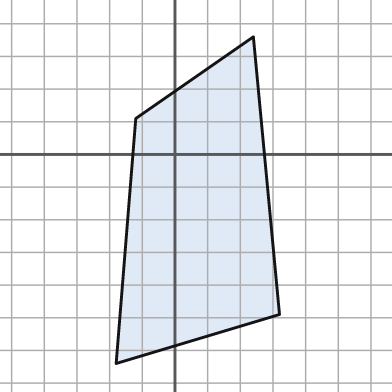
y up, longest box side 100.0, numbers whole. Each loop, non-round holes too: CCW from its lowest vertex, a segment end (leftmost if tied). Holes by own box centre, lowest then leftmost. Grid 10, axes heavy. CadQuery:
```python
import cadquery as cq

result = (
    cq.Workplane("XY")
    .moveTo(-18.0, -64.0)
    .lineTo(32.0, -49.0)
    .lineTo(24.0, 36.0)
    .lineTo(-12.0, 11.0)
    .close()
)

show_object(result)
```